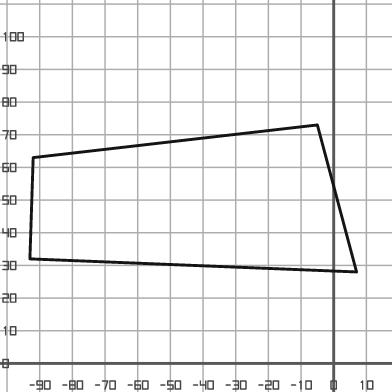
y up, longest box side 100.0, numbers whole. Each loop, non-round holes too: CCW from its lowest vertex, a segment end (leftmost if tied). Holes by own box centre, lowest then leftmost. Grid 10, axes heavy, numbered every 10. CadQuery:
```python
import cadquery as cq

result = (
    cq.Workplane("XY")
    .moveTo(7.0, 28.0)
    .lineTo(-5.0, 73.0)
    .lineTo(-92.0, 63.0)
    .lineTo(-93.0, 32.0)
    .close()
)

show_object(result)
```